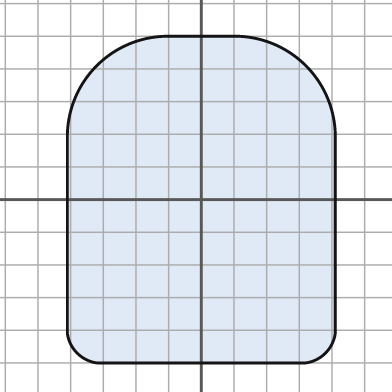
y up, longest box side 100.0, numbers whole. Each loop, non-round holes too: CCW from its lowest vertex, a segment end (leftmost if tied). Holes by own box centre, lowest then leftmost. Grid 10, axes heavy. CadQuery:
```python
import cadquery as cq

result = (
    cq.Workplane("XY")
    .moveTo(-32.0, -50.0)
    .lineTo(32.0, -50.0)
    .threePointArc((38.0, -47.0), (41.0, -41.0))
    .lineTo(41.0, 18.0)
    .threePointArc((32.0, 41.0), (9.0, 50.0))
    .lineTo(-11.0, 50.0)
    .threePointArc((-32.0, 41.0), (-41.0, 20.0))
    .lineTo(-41.0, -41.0)
    .threePointArc((-38.0, -47.0), (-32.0, -50.0))
    .close()
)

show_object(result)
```